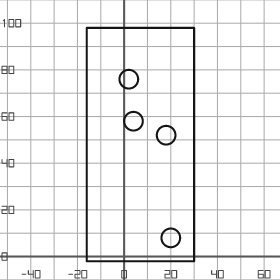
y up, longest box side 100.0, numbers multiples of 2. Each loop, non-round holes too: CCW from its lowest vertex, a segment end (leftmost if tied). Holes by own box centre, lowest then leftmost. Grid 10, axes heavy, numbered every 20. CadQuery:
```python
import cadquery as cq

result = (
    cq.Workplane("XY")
    .moveTo(-16.0, -2.0)
    .lineTo(30.0, -2.0)
    .lineTo(30.0, 98.0)
    .lineTo(-16.0, 98.0)
    .close()
    .moveTo(20.0, 8.0)
    .circle(4.0)
    .moveTo(18.0, 52.0)
    .circle(4.0)
    .moveTo(4.0, 58.0)
    .circle(4.0)
    .moveTo(2.0, 76.0)
    .circle(4.0)
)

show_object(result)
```